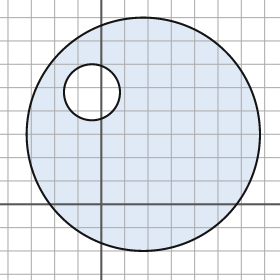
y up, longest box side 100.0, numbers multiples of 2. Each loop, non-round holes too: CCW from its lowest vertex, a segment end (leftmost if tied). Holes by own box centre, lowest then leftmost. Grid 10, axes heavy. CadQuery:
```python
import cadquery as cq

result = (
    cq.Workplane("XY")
    .moveTo(18.0, 30.0)
    .circle(50.0)
    .moveTo(-4.0, 48.0)
    .circle(12.0)
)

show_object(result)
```